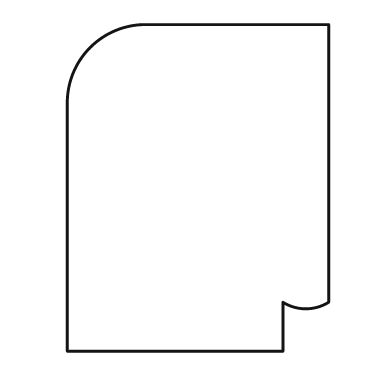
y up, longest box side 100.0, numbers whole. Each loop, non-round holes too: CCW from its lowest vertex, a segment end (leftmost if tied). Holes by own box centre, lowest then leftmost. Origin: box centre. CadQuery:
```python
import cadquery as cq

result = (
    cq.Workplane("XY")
    .moveTo(-40.0, -50.0)
    .lineTo(26.0, -50.0)
    .lineTo(26.0, -35.0)
    .threePointArc((33.0, -37.0), (40.0, -35.0))
    .lineTo(40.0, 50.0)
    .lineTo(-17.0, 50.0)
    .threePointArc((-33.0, 43.0), (-40.0, 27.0))
    .close()
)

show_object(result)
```